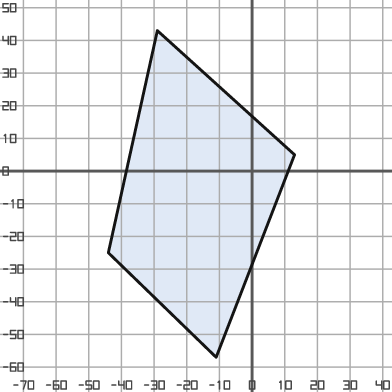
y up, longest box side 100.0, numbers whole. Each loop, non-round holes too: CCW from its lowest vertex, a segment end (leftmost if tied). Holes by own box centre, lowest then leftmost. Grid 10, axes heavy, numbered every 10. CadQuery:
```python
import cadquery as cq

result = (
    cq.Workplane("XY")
    .moveTo(-11.0, -57.0)
    .lineTo(13.0, 5.0)
    .lineTo(-29.0, 43.0)
    .lineTo(-44.0, -25.0)
    .close()
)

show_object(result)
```